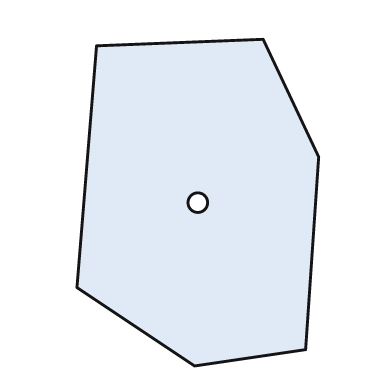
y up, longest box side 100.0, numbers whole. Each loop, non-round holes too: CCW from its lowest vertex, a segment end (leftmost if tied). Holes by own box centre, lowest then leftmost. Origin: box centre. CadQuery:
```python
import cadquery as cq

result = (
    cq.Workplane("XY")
    .moveTo(-1.0, -50.0)
    .lineTo(33.0, -45.0)
    .lineTo(37.0, 14.0)
    .lineTo(20.0, 50.0)
    .lineTo(-31.0, 48.0)
    .lineTo(-37.0, -26.0)
    .close()
    .moveTo(0.0, 0.0)
    .circle(3.0)
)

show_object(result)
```